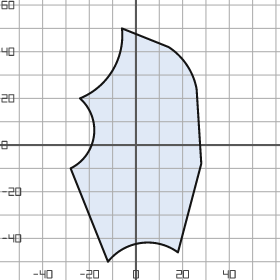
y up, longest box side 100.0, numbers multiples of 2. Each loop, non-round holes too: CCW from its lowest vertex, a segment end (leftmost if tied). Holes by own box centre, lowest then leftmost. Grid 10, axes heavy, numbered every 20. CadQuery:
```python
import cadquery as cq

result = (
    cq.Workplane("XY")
    .moveTo(-12.0, -50.0)
    .threePointArc((2.0, -42.0), (18.0, -46.0))
    .lineTo(28.0, -8.0)
    .lineTo(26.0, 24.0)
    .threePointArc((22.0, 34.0), (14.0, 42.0))
    .lineTo(-6.0, 50.0)
    .threePointArc((-10.0, 32.0), (-24.0, 20.0))
    .threePointArc((-18.0, 4.0), (-28.0, -10.0))
    .close()
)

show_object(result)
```